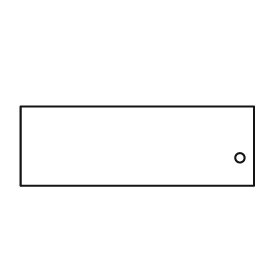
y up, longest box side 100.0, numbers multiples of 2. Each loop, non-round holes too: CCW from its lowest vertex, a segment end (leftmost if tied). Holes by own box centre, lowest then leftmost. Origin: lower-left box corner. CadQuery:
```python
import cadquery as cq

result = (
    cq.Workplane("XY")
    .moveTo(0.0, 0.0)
    .lineTo(100.0, 0.0)
    .lineTo(100.0, 34.0)
    .lineTo(0.0, 34.0)
    .close()
    .moveTo(94.0, 12.0)
    .circle(2.0)
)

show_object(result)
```